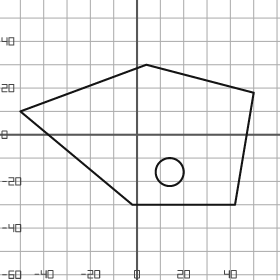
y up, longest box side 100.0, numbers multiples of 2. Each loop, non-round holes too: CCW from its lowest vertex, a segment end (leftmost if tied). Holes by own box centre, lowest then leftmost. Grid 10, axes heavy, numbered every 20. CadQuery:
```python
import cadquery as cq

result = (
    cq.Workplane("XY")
    .moveTo(-2.0, -30.0)
    .lineTo(42.0, -30.0)
    .lineTo(50.0, 18.0)
    .lineTo(4.0, 30.0)
    .lineTo(-50.0, 10.0)
    .close()
    .moveTo(14.0, -16.0)
    .circle(6.0)
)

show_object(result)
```